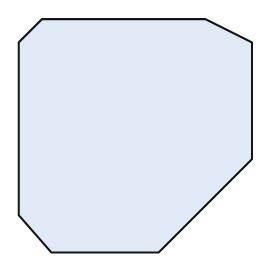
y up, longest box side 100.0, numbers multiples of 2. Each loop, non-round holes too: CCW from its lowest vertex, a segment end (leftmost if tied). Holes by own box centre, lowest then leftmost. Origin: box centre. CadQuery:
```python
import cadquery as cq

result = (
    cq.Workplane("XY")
    .moveTo(-36.0, -50.0)
    .lineTo(10.0, -50.0)
    .lineTo(50.0, -10.0)
    .lineTo(50.0, 40.0)
    .lineTo(30.0, 50.0)
    .lineTo(-40.0, 50.0)
    .lineTo(-50.0, 40.0)
    .lineTo(-50.0, -34.0)
    .close()
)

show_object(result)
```